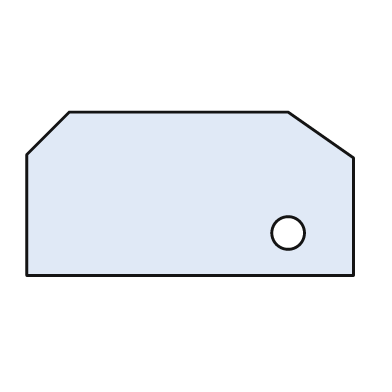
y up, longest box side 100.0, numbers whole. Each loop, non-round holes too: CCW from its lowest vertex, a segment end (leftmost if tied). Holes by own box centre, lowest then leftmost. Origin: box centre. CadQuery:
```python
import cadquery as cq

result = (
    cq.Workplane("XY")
    .moveTo(-50.0, -25.0)
    .lineTo(50.0, -25.0)
    .lineTo(50.0, 11.0)
    .lineTo(30.0, 25.0)
    .lineTo(-37.0, 25.0)
    .lineTo(-50.0, 12.0)
    .close()
    .moveTo(30.0, -12.0)
    .circle(5.0)
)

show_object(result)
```